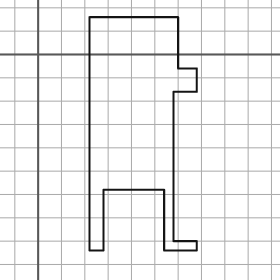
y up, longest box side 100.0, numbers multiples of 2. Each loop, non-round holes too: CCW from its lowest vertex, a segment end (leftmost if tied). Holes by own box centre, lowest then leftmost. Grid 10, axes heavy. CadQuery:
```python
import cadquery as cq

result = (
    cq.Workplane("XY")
    .moveTo(22.0, -84.0)
    .lineTo(28.0, -84.0)
    .lineTo(28.0, -58.0)
    .lineTo(54.0, -58.0)
    .lineTo(54.0, -84.0)
    .lineTo(68.0, -84.0)
    .lineTo(68.0, -80.0)
    .lineTo(58.0, -80.0)
    .lineTo(58.0, -16.0)
    .lineTo(68.0, -16.0)
    .lineTo(68.0, -6.0)
    .lineTo(60.0, -6.0)
    .lineTo(60.0, 16.0)
    .lineTo(22.0, 16.0)
    .close()
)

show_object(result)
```